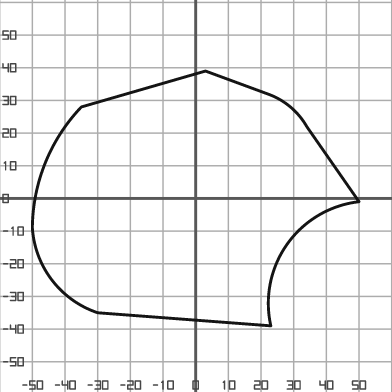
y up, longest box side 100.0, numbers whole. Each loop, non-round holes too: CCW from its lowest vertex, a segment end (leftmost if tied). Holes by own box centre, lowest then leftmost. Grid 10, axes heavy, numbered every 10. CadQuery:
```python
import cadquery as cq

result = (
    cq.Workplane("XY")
    .moveTo(23.0, -39.0)
    .threePointArc((28.0, -14.0), (50.0, -1.0))
    .lineTo(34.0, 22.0)
    .threePointArc((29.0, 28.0), (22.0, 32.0))
    .lineTo(3.0, 39.0)
    .lineTo(-35.0, 28.0)
    .threePointArc((-46.0, 11.0), (-50.0, -9.0))
    .threePointArc((-44.0, -25.0), (-30.0, -35.0))
    .close()
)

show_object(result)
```